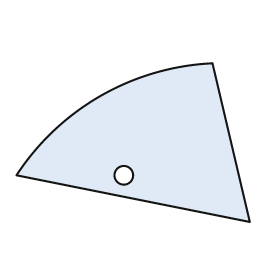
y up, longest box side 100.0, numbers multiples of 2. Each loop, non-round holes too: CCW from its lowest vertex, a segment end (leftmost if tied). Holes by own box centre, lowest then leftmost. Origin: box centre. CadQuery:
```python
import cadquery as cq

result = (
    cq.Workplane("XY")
    .moveTo(50.0, -34.0)
    .lineTo(34.0, 34.0)
    .threePointArc((-14.0, 20.0), (-50.0, -14.0))
    .close()
    .moveTo(-4.0, -14.0)
    .circle(4.0)
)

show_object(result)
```